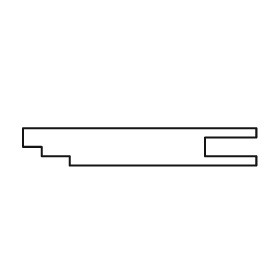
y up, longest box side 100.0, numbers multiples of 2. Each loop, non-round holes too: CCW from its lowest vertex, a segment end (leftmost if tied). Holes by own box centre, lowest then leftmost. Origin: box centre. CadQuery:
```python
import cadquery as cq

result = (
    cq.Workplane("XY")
    .moveTo(-30.0, -8.0)
    .lineTo(50.0, -8.0)
    .lineTo(50.0, -4.0)
    .lineTo(28.0, -4.0)
    .lineTo(28.0, 4.0)
    .lineTo(50.0, 4.0)
    .lineTo(50.0, 8.0)
    .lineTo(-50.0, 8.0)
    .lineTo(-50.0, 0.0)
    .lineTo(-42.0, 0.0)
    .lineTo(-42.0, -4.0)
    .lineTo(-30.0, -4.0)
    .close()
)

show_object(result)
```